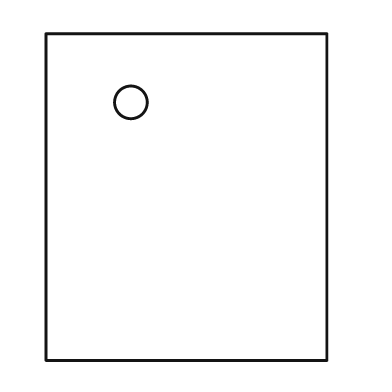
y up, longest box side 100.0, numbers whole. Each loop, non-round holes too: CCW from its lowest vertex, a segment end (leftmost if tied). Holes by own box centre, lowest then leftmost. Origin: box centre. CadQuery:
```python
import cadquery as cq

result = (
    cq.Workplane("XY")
    .moveTo(-43.0, -50.0)
    .lineTo(43.0, -50.0)
    .lineTo(43.0, 50.0)
    .lineTo(-43.0, 50.0)
    .close()
    .moveTo(-17.0, 29.0)
    .circle(5.0)
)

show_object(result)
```